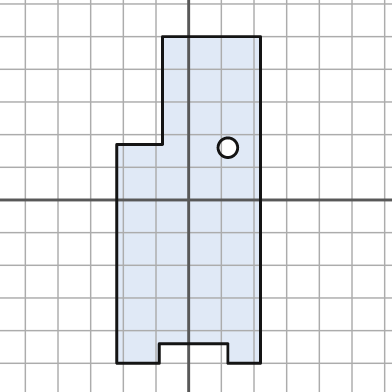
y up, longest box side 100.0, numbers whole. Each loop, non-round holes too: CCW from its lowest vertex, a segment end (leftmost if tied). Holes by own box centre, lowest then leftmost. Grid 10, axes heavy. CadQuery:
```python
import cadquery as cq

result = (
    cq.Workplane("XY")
    .moveTo(-22.0, -50.0)
    .lineTo(-9.0, -50.0)
    .lineTo(-9.0, -44.0)
    .lineTo(12.0, -44.0)
    .lineTo(12.0, -50.0)
    .lineTo(22.0, -50.0)
    .lineTo(22.0, 50.0)
    .lineTo(-8.0, 50.0)
    .lineTo(-8.0, 17.0)
    .lineTo(-22.0, 17.0)
    .close()
    .moveTo(12.0, 16.0)
    .circle(3.0)
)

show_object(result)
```